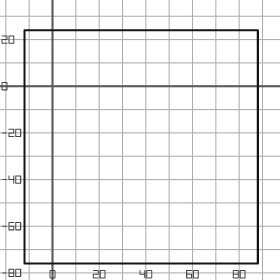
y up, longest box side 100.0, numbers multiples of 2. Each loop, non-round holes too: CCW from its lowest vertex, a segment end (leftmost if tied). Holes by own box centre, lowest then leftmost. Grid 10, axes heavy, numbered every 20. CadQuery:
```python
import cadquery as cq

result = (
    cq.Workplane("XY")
    .moveTo(-12.0, -76.0)
    .lineTo(88.0, -76.0)
    .lineTo(88.0, 24.0)
    .lineTo(-12.0, 24.0)
    .close()
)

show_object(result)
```